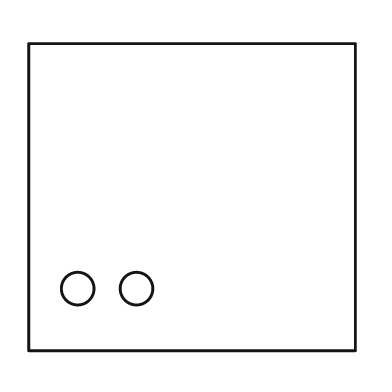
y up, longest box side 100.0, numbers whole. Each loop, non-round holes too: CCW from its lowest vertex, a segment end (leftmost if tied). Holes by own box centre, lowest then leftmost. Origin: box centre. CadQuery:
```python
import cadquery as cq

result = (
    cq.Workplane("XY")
    .moveTo(-50.0, -47.0)
    .lineTo(50.0, -47.0)
    .lineTo(50.0, 47.0)
    .lineTo(-50.0, 47.0)
    .close()
    .moveTo(-35.0, -28.0)
    .circle(5.0)
    .moveTo(-17.0, -28.0)
    .circle(5.0)
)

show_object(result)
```